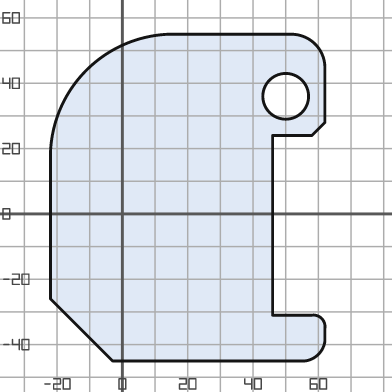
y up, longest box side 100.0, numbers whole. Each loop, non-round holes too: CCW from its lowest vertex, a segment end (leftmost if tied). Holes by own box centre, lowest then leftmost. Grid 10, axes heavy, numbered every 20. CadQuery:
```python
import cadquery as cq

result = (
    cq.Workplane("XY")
    .moveTo(-3.0, -45.0)
    .lineTo(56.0, -45.0)
    .threePointArc((60.0, -43.0), (62.0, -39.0))
    .lineTo(62.0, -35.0)
    .threePointArc((61.0, -32.0), (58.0, -31.0))
    .lineTo(46.0, -31.0)
    .lineTo(46.0, 24.0)
    .lineTo(58.0, 24.0)
    .lineTo(62.0, 28.0)
    .lineTo(62.0, 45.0)
    .threePointArc((59.0, 52.0), (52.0, 55.0))
    .lineTo(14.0, 55.0)
    .threePointArc((-11.0, 44.0), (-22.0, 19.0))
    .lineTo(-22.0, -26.0)
    .close()
    .moveTo(50.0, 36.0)
    .circle(7.0)
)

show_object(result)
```